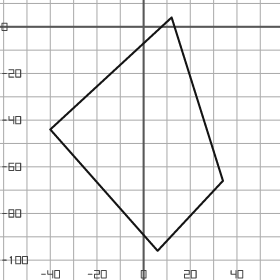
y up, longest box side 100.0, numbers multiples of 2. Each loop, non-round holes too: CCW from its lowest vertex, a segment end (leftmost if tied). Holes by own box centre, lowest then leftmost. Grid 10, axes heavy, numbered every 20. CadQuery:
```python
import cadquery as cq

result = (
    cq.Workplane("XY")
    .moveTo(6.0, -96.0)
    .lineTo(34.0, -66.0)
    .lineTo(12.0, 4.0)
    .lineTo(-40.0, -44.0)
    .close()
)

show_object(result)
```